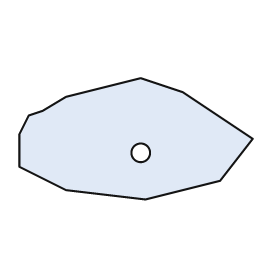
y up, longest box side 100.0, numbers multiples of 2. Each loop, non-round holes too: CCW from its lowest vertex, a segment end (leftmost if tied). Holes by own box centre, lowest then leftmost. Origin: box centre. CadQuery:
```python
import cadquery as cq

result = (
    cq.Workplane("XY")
    .moveTo(4.0, -26.0)
    .lineTo(36.0, -18.0)
    .lineTo(50.0, 0.0)
    .lineTo(20.0, 20.0)
    .lineTo(2.0, 26.0)
    .lineTo(-30.0, 18.0)
    .lineTo(-40.0, 12.0)
    .lineTo(-46.0, 10.0)
    .lineTo(-50.0, 2.0)
    .lineTo(-50.0, -12.0)
    .lineTo(-30.0, -22.0)
    .close()
    .moveTo(2.0, -6.0)
    .circle(4.0)
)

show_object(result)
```